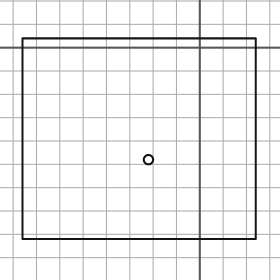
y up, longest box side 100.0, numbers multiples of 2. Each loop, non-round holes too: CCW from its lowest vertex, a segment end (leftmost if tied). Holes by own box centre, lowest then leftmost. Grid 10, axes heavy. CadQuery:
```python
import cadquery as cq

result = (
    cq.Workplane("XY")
    .moveTo(-76.0, -82.0)
    .lineTo(24.0, -82.0)
    .lineTo(24.0, 4.0)
    .lineTo(-76.0, 4.0)
    .close()
    .moveTo(-22.0, -48.0)
    .circle(2.0)
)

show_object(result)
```